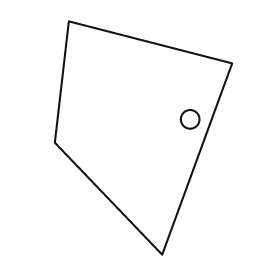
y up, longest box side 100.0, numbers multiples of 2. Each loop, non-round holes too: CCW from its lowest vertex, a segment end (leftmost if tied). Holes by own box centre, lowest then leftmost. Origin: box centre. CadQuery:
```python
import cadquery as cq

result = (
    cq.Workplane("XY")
    .moveTo(8.0, -50.0)
    .lineTo(38.0, 32.0)
    .lineTo(-32.0, 50.0)
    .lineTo(-38.0, -2.0)
    .close()
    .moveTo(20.0, 8.0)
    .circle(4.0)
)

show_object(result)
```